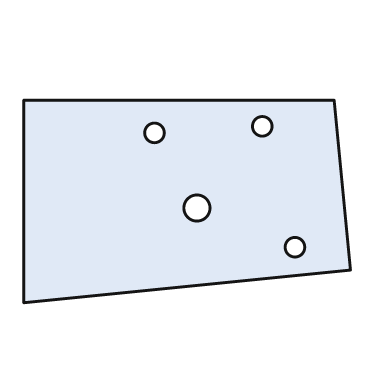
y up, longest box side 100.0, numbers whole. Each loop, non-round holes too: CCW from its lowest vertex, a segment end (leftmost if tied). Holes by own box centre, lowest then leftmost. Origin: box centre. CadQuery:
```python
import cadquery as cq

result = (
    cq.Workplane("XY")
    .moveTo(-50.0, -31.0)
    .lineTo(50.0, -21.0)
    .lineTo(45.0, 31.0)
    .lineTo(-50.0, 31.0)
    .close()
    .moveTo(33.0, -14.0)
    .circle(3.0)
    .moveTo(3.0, -2.0)
    .circle(4.0)
    .moveTo(-10.0, 21.0)
    .circle(3.0)
    .moveTo(23.0, 23.0)
    .circle(3.0)
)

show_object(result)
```